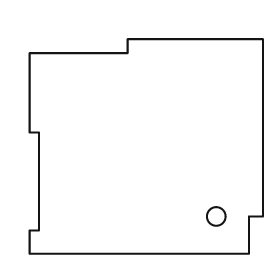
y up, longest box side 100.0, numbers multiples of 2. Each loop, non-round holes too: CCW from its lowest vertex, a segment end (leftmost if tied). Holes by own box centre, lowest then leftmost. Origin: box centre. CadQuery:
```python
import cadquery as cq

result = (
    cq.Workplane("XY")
    .moveTo(-50.0, -46.0)
    .lineTo(44.0, -46.0)
    .lineTo(44.0, -30.0)
    .lineTo(50.0, -30.0)
    .lineTo(50.0, 46.0)
    .lineTo(-8.0, 46.0)
    .lineTo(-8.0, 40.0)
    .lineTo(-50.0, 40.0)
    .lineTo(-50.0, 6.0)
    .lineTo(-46.0, 6.0)
    .lineTo(-46.0, -36.0)
    .lineTo(-50.0, -36.0)
    .close()
    .moveTo(30.0, -30.0)
    .circle(4.0)
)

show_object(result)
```